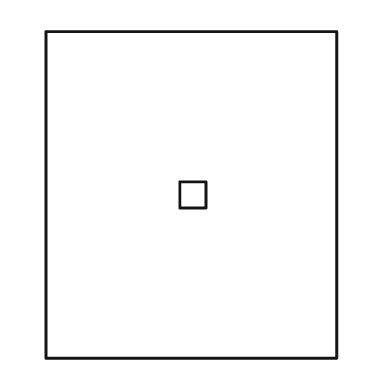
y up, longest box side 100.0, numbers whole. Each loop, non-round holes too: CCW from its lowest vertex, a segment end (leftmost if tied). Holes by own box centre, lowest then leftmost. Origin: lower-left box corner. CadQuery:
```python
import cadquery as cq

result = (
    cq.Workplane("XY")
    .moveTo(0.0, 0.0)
    .lineTo(89.0, 0.0)
    .lineTo(89.0, 100.0)
    .lineTo(0.0, 100.0)
    .close()
    .moveTo(41.0, 46.0)
    .lineTo(49.0, 46.0)
    .lineTo(49.0, 54.0)
    .lineTo(41.0, 54.0)
    .close()
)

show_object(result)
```